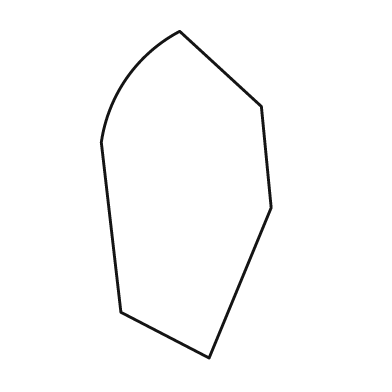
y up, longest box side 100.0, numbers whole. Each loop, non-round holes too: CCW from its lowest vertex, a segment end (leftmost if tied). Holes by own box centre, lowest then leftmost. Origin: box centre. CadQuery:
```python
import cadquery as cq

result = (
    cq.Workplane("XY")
    .moveTo(7.0, -50.0)
    .lineTo(26.0, -4.0)
    .lineTo(23.0, 27.0)
    .lineTo(-2.0, 50.0)
    .threePointArc((-18.0, 36.0), (-26.0, 16.0))
    .lineTo(-20.0, -36.0)
    .close()
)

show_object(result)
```